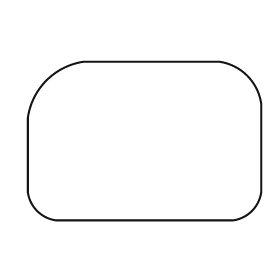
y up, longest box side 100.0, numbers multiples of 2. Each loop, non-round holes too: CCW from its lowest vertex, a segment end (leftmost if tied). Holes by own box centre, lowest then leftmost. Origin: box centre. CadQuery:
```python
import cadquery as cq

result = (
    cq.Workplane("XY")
    .moveTo(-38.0, -34.0)
    .lineTo(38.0, -34.0)
    .threePointArc((46.0, -30.0), (50.0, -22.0))
    .lineTo(50.0, 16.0)
    .threePointArc((44.0, 28.0), (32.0, 34.0))
    .lineTo(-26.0, 34.0)
    .threePointArc((-42.0, 26.0), (-50.0, 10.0))
    .lineTo(-50.0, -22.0)
    .threePointArc((-46.0, -30.0), (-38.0, -34.0))
    .close()
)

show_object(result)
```